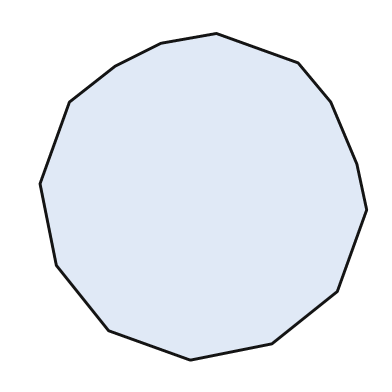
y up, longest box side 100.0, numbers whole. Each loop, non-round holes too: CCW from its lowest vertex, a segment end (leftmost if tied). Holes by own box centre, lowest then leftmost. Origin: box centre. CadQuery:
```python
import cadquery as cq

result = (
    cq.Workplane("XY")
    .moveTo(-4.0, -50.0)
    .lineTo(21.0, -45.0)
    .lineTo(41.0, -29.0)
    .lineTo(50.0, -4.0)
    .lineTo(47.0, 10.0)
    .lineTo(39.0, 29.0)
    .lineTo(29.0, 41.0)
    .lineTo(4.0, 50.0)
    .lineTo(-13.0, 47.0)
    .lineTo(-27.0, 40.0)
    .lineTo(-41.0, 29.0)
    .lineTo(-50.0, 4.0)
    .lineTo(-45.0, -21.0)
    .lineTo(-29.0, -41.0)
    .close()
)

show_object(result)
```